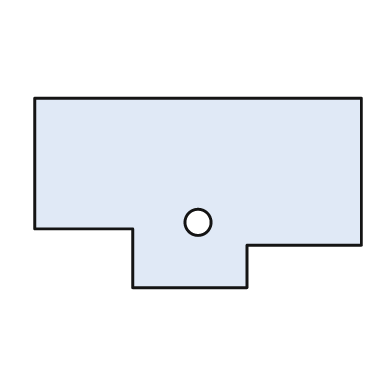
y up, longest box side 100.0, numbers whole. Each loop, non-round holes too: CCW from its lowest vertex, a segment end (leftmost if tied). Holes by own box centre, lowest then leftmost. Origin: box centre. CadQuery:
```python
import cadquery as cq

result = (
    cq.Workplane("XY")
    .moveTo(-20.0, -29.0)
    .lineTo(15.0, -29.0)
    .lineTo(15.0, -16.0)
    .lineTo(50.0, -16.0)
    .lineTo(50.0, 29.0)
    .lineTo(-50.0, 29.0)
    .lineTo(-50.0, -11.0)
    .lineTo(-20.0, -11.0)
    .close()
    .moveTo(0.0, -9.0)
    .circle(4.0)
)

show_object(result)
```